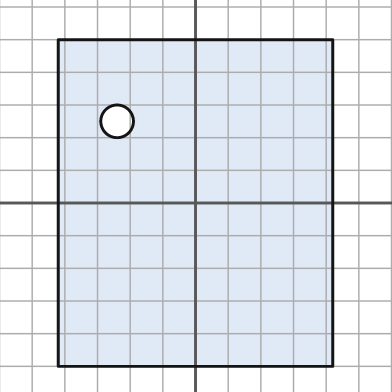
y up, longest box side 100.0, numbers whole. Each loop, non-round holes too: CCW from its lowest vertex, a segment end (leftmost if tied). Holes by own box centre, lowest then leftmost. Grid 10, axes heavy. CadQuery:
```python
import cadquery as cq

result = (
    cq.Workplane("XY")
    .moveTo(-42.0, -50.0)
    .lineTo(42.0, -50.0)
    .lineTo(42.0, 50.0)
    .lineTo(-42.0, 50.0)
    .close()
    .moveTo(-24.0, 25.0)
    .circle(5.0)
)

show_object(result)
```